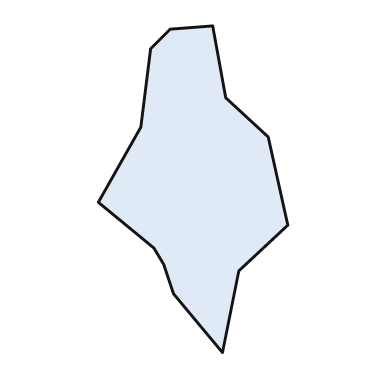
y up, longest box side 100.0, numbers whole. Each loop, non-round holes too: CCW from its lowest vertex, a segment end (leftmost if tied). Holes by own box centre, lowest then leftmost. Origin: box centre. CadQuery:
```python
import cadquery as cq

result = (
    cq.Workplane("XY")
    .moveTo(9.0, -50.0)
    .lineTo(14.0, -25.0)
    .lineTo(29.0, -11.0)
    .lineTo(23.0, 16.0)
    .lineTo(10.0, 28.0)
    .lineTo(6.0, 50.0)
    .lineTo(-7.0, 49.0)
    .lineTo(-13.0, 43.0)
    .lineTo(-16.0, 19.0)
    .lineTo(-29.0, -4.0)
    .lineTo(-12.0, -18.0)
    .lineTo(-9.0, -23.0)
    .lineTo(-6.0, -32.0)
    .close()
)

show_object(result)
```